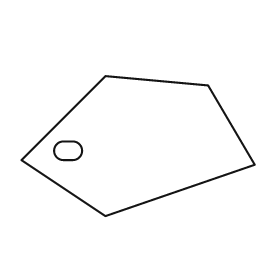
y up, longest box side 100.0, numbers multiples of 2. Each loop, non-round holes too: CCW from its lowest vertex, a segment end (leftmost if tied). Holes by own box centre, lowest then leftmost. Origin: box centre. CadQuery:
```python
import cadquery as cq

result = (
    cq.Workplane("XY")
    .moveTo(-14.0, -30.0)
    .lineTo(50.0, -8.0)
    .lineTo(30.0, 26.0)
    .lineTo(-14.0, 30.0)
    .lineTo(-50.0, -6.0)
    .close()
    .moveTo(-32.0, -6.0)
    .lineTo(-28.0, -6.0)
    .threePointArc((-24.0, -2.0), (-28.0, 2.0))
    .lineTo(-32.0, 2.0)
    .threePointArc((-36.0, -2.0), (-32.0, -6.0))
    .close()
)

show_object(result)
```